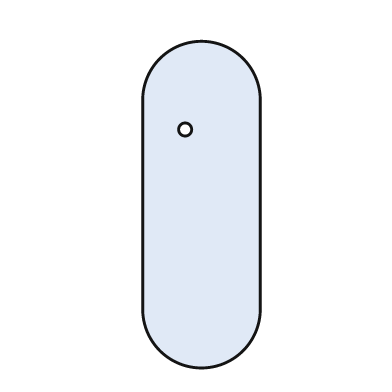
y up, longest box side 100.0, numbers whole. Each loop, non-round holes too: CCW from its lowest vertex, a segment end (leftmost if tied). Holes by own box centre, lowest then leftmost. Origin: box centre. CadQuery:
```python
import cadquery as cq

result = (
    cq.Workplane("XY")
    .moveTo(-18.0, -32.0)
    .threePointArc((0.0, -50.0), (18.0, -32.0))
    .lineTo(18.0, 32.0)
    .threePointArc((0.0, 50.0), (-18.0, 32.0))
    .close()
    .moveTo(-5.0, 23.0)
    .circle(2.0)
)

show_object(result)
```